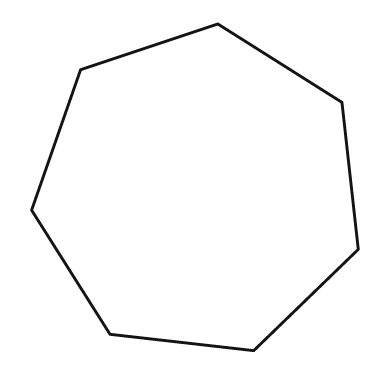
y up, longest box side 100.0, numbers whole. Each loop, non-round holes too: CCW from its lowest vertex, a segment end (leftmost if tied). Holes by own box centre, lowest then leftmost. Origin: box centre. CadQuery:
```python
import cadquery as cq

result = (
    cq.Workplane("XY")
    .moveTo(18.0, -50.0)
    .lineTo(50.0, -19.0)
    .lineTo(45.0, 26.0)
    .lineTo(7.0, 50.0)
    .lineTo(-35.0, 36.0)
    .lineTo(-50.0, -7.0)
    .lineTo(-26.0, -45.0)
    .close()
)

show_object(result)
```